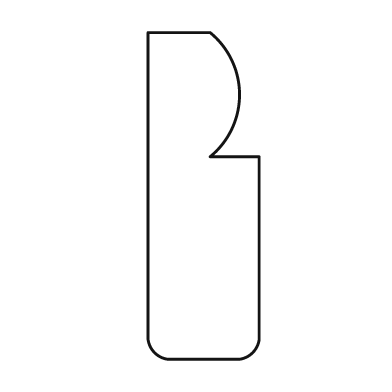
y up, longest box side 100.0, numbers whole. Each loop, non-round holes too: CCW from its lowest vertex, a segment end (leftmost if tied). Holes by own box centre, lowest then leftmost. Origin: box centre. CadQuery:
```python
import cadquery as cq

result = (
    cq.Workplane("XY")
    .moveTo(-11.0, -50.0)
    .lineTo(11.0, -50.0)
    .threePointArc((15.0, -48.0), (17.0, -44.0))
    .lineTo(17.0, 12.0)
    .lineTo(2.0, 12.0)
    .threePointArc((11.0, 31.0), (2.0, 50.0))
    .lineTo(-17.0, 50.0)
    .lineTo(-17.0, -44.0)
    .threePointArc((-15.0, -48.0), (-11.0, -50.0))
    .close()
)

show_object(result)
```